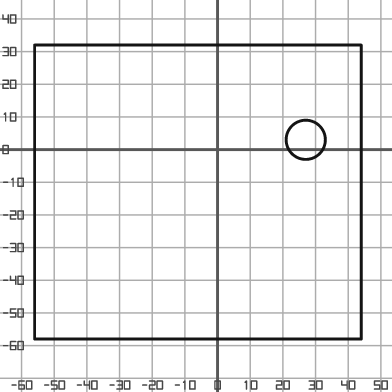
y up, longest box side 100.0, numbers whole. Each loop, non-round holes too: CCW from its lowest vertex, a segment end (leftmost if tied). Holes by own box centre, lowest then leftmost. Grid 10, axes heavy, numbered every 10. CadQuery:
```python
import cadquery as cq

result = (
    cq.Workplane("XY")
    .moveTo(-56.0, -58.0)
    .lineTo(44.0, -58.0)
    .lineTo(44.0, 32.0)
    .lineTo(-56.0, 32.0)
    .close()
    .moveTo(27.0, 3.0)
    .circle(6.0)
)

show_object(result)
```